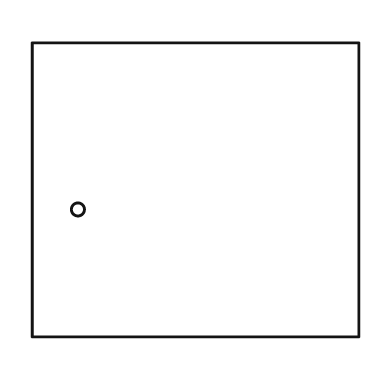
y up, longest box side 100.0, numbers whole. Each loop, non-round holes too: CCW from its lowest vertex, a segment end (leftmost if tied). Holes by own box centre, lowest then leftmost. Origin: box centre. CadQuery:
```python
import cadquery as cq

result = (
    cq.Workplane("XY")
    .moveTo(-50.0, -45.0)
    .lineTo(50.0, -45.0)
    .lineTo(50.0, 45.0)
    .lineTo(-50.0, 45.0)
    .close()
    .moveTo(-36.0, -6.0)
    .circle(2.0)
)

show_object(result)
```